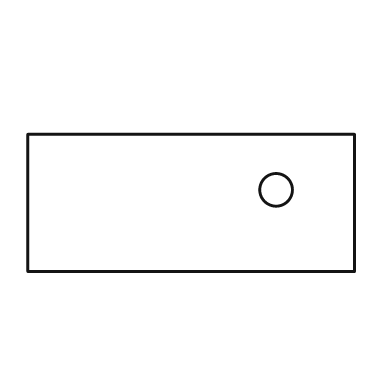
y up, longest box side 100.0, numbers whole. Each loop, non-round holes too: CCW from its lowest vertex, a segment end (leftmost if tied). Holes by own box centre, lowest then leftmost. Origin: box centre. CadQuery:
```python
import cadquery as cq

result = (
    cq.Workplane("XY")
    .moveTo(-50.0, -21.0)
    .lineTo(50.0, -21.0)
    .lineTo(50.0, 21.0)
    .lineTo(-50.0, 21.0)
    .close()
    .moveTo(26.0, 4.0)
    .circle(5.0)
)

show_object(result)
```